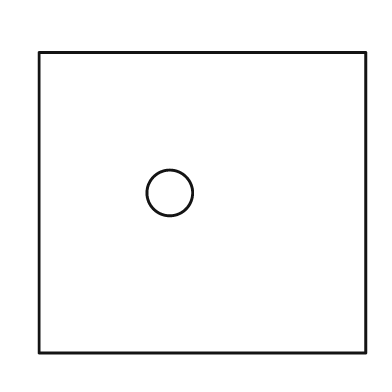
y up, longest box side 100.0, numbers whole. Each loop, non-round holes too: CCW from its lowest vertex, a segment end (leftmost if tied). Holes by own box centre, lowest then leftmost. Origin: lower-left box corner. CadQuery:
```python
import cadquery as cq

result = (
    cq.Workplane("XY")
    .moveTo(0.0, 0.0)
    .lineTo(100.0, 0.0)
    .lineTo(100.0, 92.0)
    .lineTo(0.0, 92.0)
    .close()
    .moveTo(40.0, 49.0)
    .circle(7.0)
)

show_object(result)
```